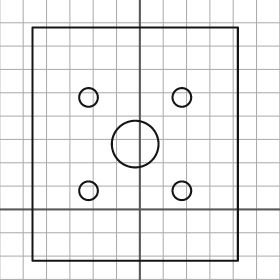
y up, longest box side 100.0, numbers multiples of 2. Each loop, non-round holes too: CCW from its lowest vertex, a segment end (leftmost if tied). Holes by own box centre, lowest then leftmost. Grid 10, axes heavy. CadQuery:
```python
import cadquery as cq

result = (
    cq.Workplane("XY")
    .moveTo(-46.0, -22.0)
    .lineTo(42.0, -22.0)
    .lineTo(42.0, 78.0)
    .lineTo(-46.0, 78.0)
    .close()
    .moveTo(-22.0, 8.0)
    .circle(4.0)
    .moveTo(18.0, 8.0)
    .circle(4.0)
    .moveTo(-2.0, 28.0)
    .circle(10.0)
    .moveTo(-22.0, 48.0)
    .circle(4.0)
    .moveTo(18.0, 48.0)
    .circle(4.0)
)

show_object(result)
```